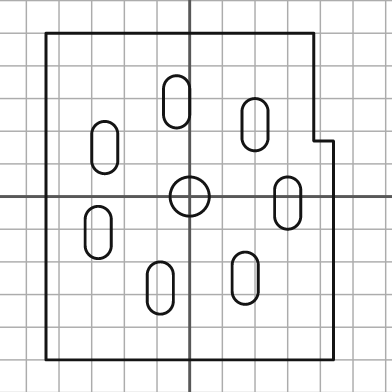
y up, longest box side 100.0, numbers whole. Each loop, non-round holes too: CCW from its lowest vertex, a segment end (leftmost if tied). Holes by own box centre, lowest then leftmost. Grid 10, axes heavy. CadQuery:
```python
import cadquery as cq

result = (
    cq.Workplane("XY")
    .moveTo(-44.0, -50.0)
    .lineTo(44.0, -50.0)
    .lineTo(44.0, 17.0)
    .lineTo(38.0, 17.0)
    .lineTo(38.0, 50.0)
    .lineTo(-44.0, 50.0)
    .close()
    .moveTo(-13.0, -32.0)
    .threePointArc((-9.0, -36.0), (-5.0, -32.0))
    .lineTo(-5.0, -24.0)
    .threePointArc((-9.0, -20.0), (-13.0, -24.0))
    .close()
    .moveTo(13.0, -29.0)
    .threePointArc((17.0, -33.0), (21.0, -29.0))
    .lineTo(21.0, -21.0)
    .threePointArc((17.0, -17.0), (13.0, -21.0))
    .close()
    .moveTo(-32.0, -15.0)
    .threePointArc((-28.0, -19.0), (-24.0, -15.0))
    .lineTo(-24.0, -7.0)
    .threePointArc((-28.0, -3.0), (-32.0, -7.0))
    .close()
    .moveTo(26.0, -6.0)
    .threePointArc((30.0, -10.0), (34.0, -6.0))
    .lineTo(34.0, 2.0)
    .threePointArc((30.0, 6.0), (26.0, 2.0))
    .close()
    .moveTo(0.0, 0.0)
    .circle(6.0)
    .moveTo(-30.0, 11.0)
    .threePointArc((-26.0, 7.0), (-22.0, 11.0))
    .lineTo(-22.0, 19.0)
    .threePointArc((-26.0, 23.0), (-30.0, 19.0))
    .close()
    .moveTo(16.0, 18.0)
    .threePointArc((20.0, 14.0), (24.0, 18.0))
    .lineTo(24.0, 26.0)
    .threePointArc((20.0, 30.0), (16.0, 26.0))
    .close()
    .moveTo(-8.0, 25.0)
    .threePointArc((-4.0, 21.0), (0.0, 25.0))
    .lineTo(0.0, 33.0)
    .threePointArc((-4.0, 37.0), (-8.0, 33.0))
    .close()
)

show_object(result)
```